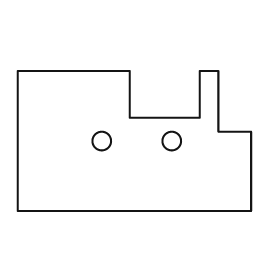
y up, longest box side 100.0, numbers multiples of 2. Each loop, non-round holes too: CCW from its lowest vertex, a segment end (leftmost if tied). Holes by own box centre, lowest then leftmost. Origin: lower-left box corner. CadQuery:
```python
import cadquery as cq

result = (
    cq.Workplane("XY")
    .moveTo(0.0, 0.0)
    .lineTo(100.0, 0.0)
    .lineTo(100.0, 34.0)
    .lineTo(86.0, 34.0)
    .lineTo(86.0, 60.0)
    .lineTo(78.0, 60.0)
    .lineTo(78.0, 40.0)
    .lineTo(48.0, 40.0)
    .lineTo(48.0, 60.0)
    .lineTo(0.0, 60.0)
    .close()
    .moveTo(36.0, 30.0)
    .circle(4.0)
    .moveTo(66.0, 30.0)
    .circle(4.0)
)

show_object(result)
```